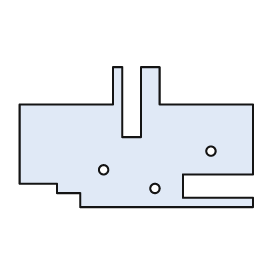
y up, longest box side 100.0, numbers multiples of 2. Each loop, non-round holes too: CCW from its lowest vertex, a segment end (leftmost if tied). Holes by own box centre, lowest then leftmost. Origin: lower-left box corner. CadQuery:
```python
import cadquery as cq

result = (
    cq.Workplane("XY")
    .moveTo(26.0, 0.0)
    .lineTo(100.0, 0.0)
    .lineTo(100.0, 4.0)
    .lineTo(70.0, 4.0)
    .lineTo(70.0, 14.0)
    .lineTo(100.0, 14.0)
    .lineTo(100.0, 44.0)
    .lineTo(60.0, 44.0)
    .lineTo(60.0, 60.0)
    .lineTo(52.0, 60.0)
    .lineTo(52.0, 30.0)
    .lineTo(44.0, 30.0)
    .lineTo(44.0, 60.0)
    .lineTo(40.0, 60.0)
    .lineTo(40.0, 44.0)
    .lineTo(0.0, 44.0)
    .lineTo(0.0, 10.0)
    .lineTo(16.0, 10.0)
    .lineTo(16.0, 6.0)
    .lineTo(26.0, 6.0)
    .close()
    .moveTo(58.0, 8.0)
    .circle(2.0)
    .moveTo(36.0, 16.0)
    .circle(2.0)
    .moveTo(82.0, 24.0)
    .circle(2.0)
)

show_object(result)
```